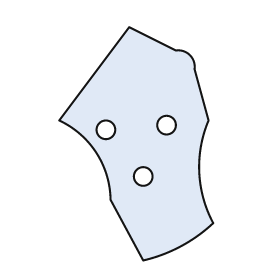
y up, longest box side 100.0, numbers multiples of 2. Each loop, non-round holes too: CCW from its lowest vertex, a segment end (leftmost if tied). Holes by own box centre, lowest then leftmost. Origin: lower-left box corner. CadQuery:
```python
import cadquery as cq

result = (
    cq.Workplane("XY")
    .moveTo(36.0, 0.0)
    .threePointArc((52.0, 6.0), (66.0, 16.0))
    .threePointArc((60.0, 38.0), (64.0, 60.0))
    .lineTo(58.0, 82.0)
    .threePointArc((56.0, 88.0), (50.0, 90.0))
    .lineTo(30.0, 100.0)
    .lineTo(0.0, 60.0)
    .threePointArc((16.0, 46.0), (22.0, 26.0))
    .close()
    .moveTo(36.0, 36.0)
    .circle(4.0)
    .moveTo(20.0, 56.0)
    .circle(4.0)
    .moveTo(46.0, 58.0)
    .circle(4.0)
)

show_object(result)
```